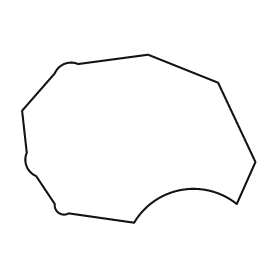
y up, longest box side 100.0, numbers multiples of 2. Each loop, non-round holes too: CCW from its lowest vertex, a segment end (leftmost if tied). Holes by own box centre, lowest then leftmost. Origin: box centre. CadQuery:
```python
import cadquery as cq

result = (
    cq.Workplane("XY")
    .moveTo(-2.0, -36.0)
    .threePointArc((18.0, -22.0), (42.0, -28.0))
    .lineTo(50.0, -10.0)
    .lineTo(34.0, 24.0)
    .lineTo(4.0, 36.0)
    .lineTo(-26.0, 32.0)
    .threePointArc((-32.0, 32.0), (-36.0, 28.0))
    .lineTo(-50.0, 12.0)
    .lineTo(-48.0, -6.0)
    .threePointArc((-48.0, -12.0), (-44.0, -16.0))
    .lineTo(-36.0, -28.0)
    .threePointArc((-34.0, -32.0), (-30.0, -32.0))
    .close()
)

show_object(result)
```